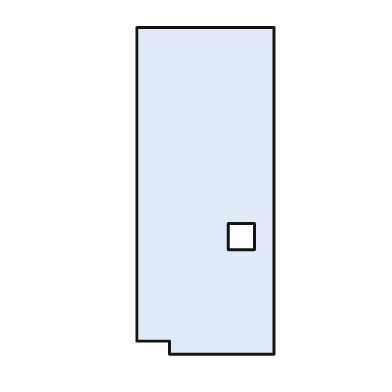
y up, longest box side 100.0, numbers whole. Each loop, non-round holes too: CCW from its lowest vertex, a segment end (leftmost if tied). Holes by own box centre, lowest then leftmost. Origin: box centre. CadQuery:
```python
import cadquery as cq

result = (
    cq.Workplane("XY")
    .moveTo(-11.0, -50.0)
    .lineTo(21.0, -50.0)
    .lineTo(21.0, 50.0)
    .lineTo(-21.0, 50.0)
    .lineTo(-21.0, -46.0)
    .lineTo(-11.0, -46.0)
    .close()
    .moveTo(7.0, -18.0)
    .lineTo(15.0, -18.0)
    .lineTo(15.0, -10.0)
    .lineTo(7.0, -10.0)
    .close()
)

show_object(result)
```